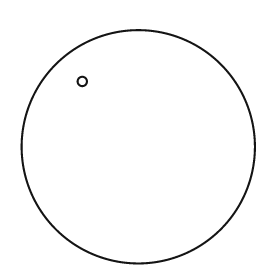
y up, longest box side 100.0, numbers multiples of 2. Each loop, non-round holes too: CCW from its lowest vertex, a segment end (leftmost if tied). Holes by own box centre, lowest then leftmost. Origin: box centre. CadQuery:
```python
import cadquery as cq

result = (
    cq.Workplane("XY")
    .moveTo(0.0, 0.0)
    .circle(50.0)
    .moveTo(-24.0, 28.0)
    .circle(2.0)
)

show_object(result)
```